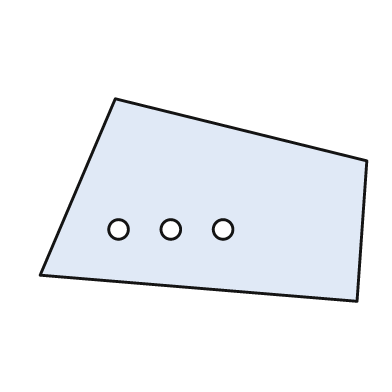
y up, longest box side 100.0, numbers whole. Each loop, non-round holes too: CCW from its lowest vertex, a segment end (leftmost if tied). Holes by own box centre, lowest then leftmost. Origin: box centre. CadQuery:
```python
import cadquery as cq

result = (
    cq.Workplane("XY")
    .moveTo(47.0, -31.0)
    .lineTo(50.0, 12.0)
    .lineTo(-27.0, 31.0)
    .lineTo(-50.0, -23.0)
    .close()
    .moveTo(-26.0, -9.0)
    .circle(3.0)
    .moveTo(-10.0, -9.0)
    .circle(3.0)
    .moveTo(6.0, -9.0)
    .circle(3.0)
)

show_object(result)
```